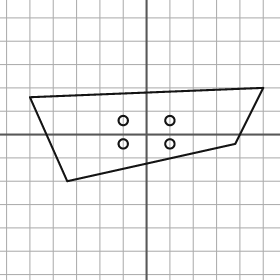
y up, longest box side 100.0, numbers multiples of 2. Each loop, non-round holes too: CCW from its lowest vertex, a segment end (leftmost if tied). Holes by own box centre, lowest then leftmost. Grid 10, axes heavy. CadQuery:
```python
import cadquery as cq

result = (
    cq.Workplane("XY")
    .moveTo(-34.0, -20.0)
    .lineTo(38.0, -4.0)
    .lineTo(50.0, 20.0)
    .lineTo(-50.0, 16.0)
    .close()
    .moveTo(-10.0, -4.0)
    .circle(2.0)
    .moveTo(10.0, -4.0)
    .circle(2.0)
    .moveTo(-10.0, 6.0)
    .circle(2.0)
    .moveTo(10.0, 6.0)
    .circle(2.0)
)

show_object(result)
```